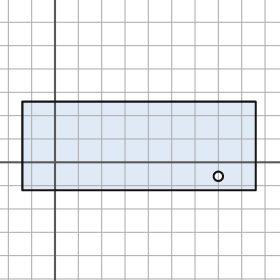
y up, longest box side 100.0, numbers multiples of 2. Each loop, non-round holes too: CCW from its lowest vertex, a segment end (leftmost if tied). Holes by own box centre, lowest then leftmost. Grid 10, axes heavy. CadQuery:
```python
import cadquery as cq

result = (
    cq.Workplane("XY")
    .moveTo(-14.0, -12.0)
    .lineTo(86.0, -12.0)
    .lineTo(86.0, 26.0)
    .lineTo(-14.0, 26.0)
    .close()
    .moveTo(70.0, -6.0)
    .circle(2.0)
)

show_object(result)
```